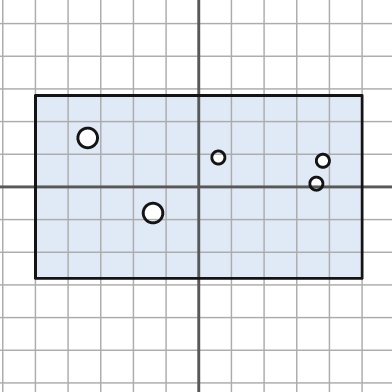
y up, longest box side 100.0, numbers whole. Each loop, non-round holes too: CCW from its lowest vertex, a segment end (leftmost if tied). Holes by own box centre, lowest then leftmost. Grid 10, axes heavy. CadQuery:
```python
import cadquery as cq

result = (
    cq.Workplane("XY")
    .moveTo(-50.0, -28.0)
    .lineTo(50.0, -28.0)
    .lineTo(50.0, 28.0)
    .lineTo(-50.0, 28.0)
    .close()
    .moveTo(-14.0, -8.0)
    .circle(3.0)
    .moveTo(36.0, 1.0)
    .circle(2.0)
    .moveTo(38.0, 8.0)
    .circle(2.0)
    .moveTo(6.0, 9.0)
    .circle(2.0)
    .moveTo(-34.0, 15.0)
    .circle(3.0)
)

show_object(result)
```